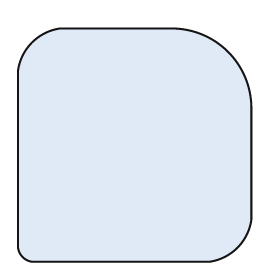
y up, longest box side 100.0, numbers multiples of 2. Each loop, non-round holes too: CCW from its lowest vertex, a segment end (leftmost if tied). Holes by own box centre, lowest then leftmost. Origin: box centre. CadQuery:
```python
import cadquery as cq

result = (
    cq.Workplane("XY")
    .moveTo(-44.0, -50.0)
    .lineTo(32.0, -50.0)
    .threePointArc((44.0, -44.0), (50.0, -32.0))
    .lineTo(50.0, 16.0)
    .threePointArc((40.0, 40.0), (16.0, 50.0))
    .lineTo(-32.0, 50.0)
    .threePointArc((-44.0, 44.0), (-50.0, 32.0))
    .lineTo(-50.0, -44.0)
    .threePointArc((-48.0, -48.0), (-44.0, -50.0))
    .close()
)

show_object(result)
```